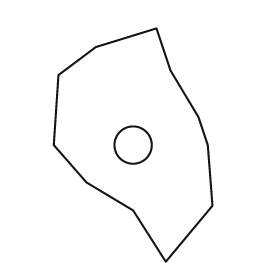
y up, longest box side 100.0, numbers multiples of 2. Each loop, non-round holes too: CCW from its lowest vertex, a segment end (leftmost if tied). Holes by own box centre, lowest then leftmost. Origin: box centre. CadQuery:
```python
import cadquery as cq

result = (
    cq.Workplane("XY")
    .moveTo(14.0, -50.0)
    .lineTo(34.0, -26.0)
    .lineTo(32.0, 0.0)
    .lineTo(28.0, 12.0)
    .lineTo(16.0, 32.0)
    .lineTo(10.0, 50.0)
    .lineTo(-16.0, 42.0)
    .lineTo(-32.0, 30.0)
    .lineTo(-34.0, 0.0)
    .lineTo(-20.0, -16.0)
    .lineTo(0.0, -28.0)
    .close()
    .moveTo(0.0, 0.0)
    .circle(8.0)
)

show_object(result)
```